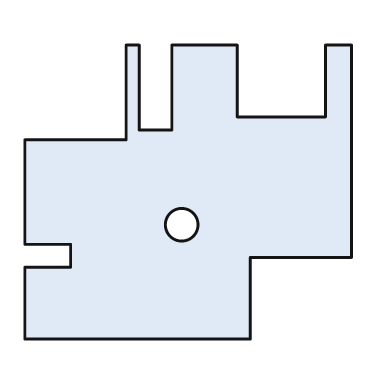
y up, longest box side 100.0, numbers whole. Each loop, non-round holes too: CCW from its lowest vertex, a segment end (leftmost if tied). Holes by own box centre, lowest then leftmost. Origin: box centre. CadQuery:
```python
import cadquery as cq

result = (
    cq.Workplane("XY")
    .moveTo(-50.0, -45.0)
    .lineTo(19.0, -45.0)
    .lineTo(19.0, -20.0)
    .lineTo(50.0, -20.0)
    .lineTo(50.0, 45.0)
    .lineTo(42.0, 45.0)
    .lineTo(42.0, 23.0)
    .lineTo(15.0, 23.0)
    .lineTo(15.0, 45.0)
    .lineTo(-5.0, 45.0)
    .lineTo(-5.0, 19.0)
    .lineTo(-15.0, 19.0)
    .lineTo(-15.0, 45.0)
    .lineTo(-19.0, 45.0)
    .lineTo(-19.0, 16.0)
    .lineTo(-50.0, 16.0)
    .lineTo(-50.0, -16.0)
    .lineTo(-36.0, -16.0)
    .lineTo(-36.0, -23.0)
    .lineTo(-50.0, -23.0)
    .close()
    .moveTo(-2.0, -10.0)
    .circle(5.0)
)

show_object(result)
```